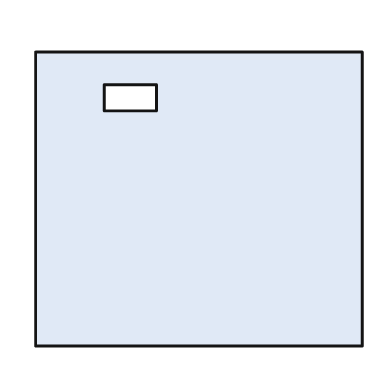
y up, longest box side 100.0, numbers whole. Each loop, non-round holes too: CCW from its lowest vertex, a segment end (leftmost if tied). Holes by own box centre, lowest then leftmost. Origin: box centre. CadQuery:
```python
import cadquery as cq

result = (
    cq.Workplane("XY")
    .moveTo(-50.0, -45.0)
    .lineTo(50.0, -45.0)
    .lineTo(50.0, 45.0)
    .lineTo(-50.0, 45.0)
    .close()
    .moveTo(-29.0, 27.0)
    .lineTo(-13.0, 27.0)
    .lineTo(-13.0, 35.0)
    .lineTo(-29.0, 35.0)
    .close()
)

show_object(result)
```